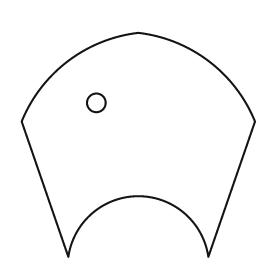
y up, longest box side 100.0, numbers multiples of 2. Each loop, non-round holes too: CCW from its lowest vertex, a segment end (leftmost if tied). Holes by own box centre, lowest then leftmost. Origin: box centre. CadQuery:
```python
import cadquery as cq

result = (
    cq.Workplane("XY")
    .moveTo(-30.0, -48.0)
    .threePointArc((0.0, -22.0), (30.0, -48.0))
    .lineTo(50.0, 10.0)
    .threePointArc((30.0, 36.0), (0.0, 48.0))
    .threePointArc((-30.0, 36.0), (-50.0, 10.0))
    .close()
    .moveTo(-18.0, 18.0)
    .circle(4.0)
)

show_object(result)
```